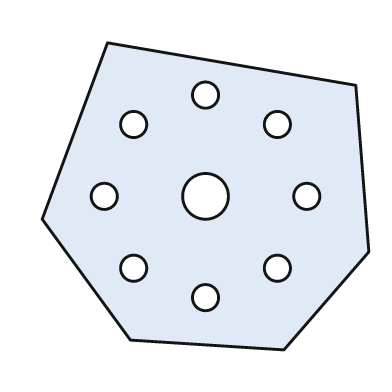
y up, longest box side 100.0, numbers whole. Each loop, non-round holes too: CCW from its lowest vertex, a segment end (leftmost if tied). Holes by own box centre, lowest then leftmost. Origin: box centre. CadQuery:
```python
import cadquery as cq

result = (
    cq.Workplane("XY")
    .moveTo(24.0, -47.0)
    .lineTo(50.0, -17.0)
    .lineTo(46.0, 34.0)
    .lineTo(-30.0, 47.0)
    .lineTo(-50.0, -7.0)
    .lineTo(-23.0, -44.0)
    .close()
    .moveTo(0.0, -31.0)
    .circle(4.0)
    .moveTo(-22.0, -22.0)
    .circle(4.0)
    .moveTo(22.0, -22.0)
    .circle(4.0)
    .moveTo(-31.0, 0.0)
    .circle(4.0)
    .moveTo(0.0, 0.0)
    .circle(7.0)
    .moveTo(31.0, 0.0)
    .circle(4.0)
    .moveTo(-22.0, 22.0)
    .circle(4.0)
    .moveTo(22.0, 22.0)
    .circle(4.0)
    .moveTo(0.0, 31.0)
    .circle(4.0)
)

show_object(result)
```